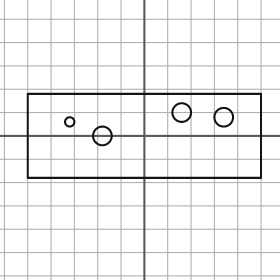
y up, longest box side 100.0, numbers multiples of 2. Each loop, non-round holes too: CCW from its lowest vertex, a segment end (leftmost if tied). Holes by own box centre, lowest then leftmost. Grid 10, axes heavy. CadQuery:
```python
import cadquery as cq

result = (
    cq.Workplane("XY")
    .moveTo(-50.0, -18.0)
    .lineTo(50.0, -18.0)
    .lineTo(50.0, 18.0)
    .lineTo(-50.0, 18.0)
    .close()
    .moveTo(-18.0, 0.0)
    .circle(4.0)
    .moveTo(-32.0, 6.0)
    .circle(2.0)
    .moveTo(34.0, 8.0)
    .circle(4.0)
    .moveTo(16.0, 10.0)
    .circle(4.0)
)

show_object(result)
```